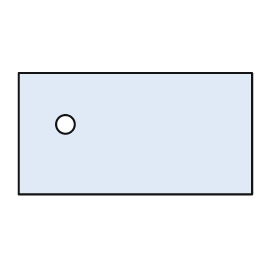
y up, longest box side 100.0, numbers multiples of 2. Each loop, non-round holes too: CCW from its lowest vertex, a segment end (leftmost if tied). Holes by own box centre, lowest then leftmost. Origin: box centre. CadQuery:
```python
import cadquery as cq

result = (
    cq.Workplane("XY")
    .moveTo(-50.0, -26.0)
    .lineTo(50.0, -26.0)
    .lineTo(50.0, 26.0)
    .lineTo(-50.0, 26.0)
    .close()
    .moveTo(-30.0, 4.0)
    .circle(4.0)
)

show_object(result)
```